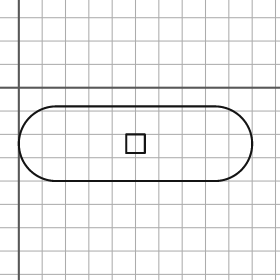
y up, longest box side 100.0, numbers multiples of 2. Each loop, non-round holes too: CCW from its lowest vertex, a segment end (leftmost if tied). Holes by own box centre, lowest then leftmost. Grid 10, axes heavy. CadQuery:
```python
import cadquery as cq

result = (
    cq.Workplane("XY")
    .moveTo(16.0, -40.0)
    .lineTo(84.0, -40.0)
    .threePointArc((100.0, -24.0), (84.0, -8.0))
    .lineTo(16.0, -8.0)
    .threePointArc((0.0, -24.0), (16.0, -40.0))
    .close()
    .moveTo(46.0, -28.0)
    .lineTo(54.0, -28.0)
    .lineTo(54.0, -20.0)
    .lineTo(46.0, -20.0)
    .close()
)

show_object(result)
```